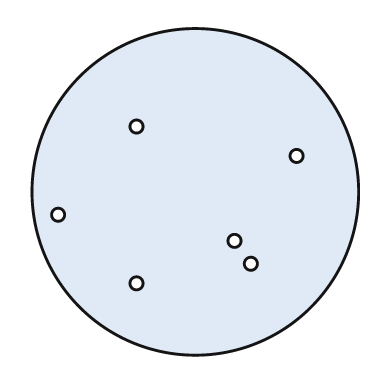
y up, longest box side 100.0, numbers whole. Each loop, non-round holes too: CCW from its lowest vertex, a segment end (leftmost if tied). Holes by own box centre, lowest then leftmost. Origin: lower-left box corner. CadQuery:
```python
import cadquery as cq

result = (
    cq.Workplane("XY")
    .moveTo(50.0, 50.0)
    .circle(50.0)
    .moveTo(32.0, 22.0)
    .circle(2.0)
    .moveTo(67.0, 28.0)
    .circle(2.0)
    .moveTo(62.0, 35.0)
    .circle(2.0)
    .moveTo(8.0, 43.0)
    .circle(2.0)
    .moveTo(81.0, 61.0)
    .circle(2.0)
    .moveTo(32.0, 70.0)
    .circle(2.0)
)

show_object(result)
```